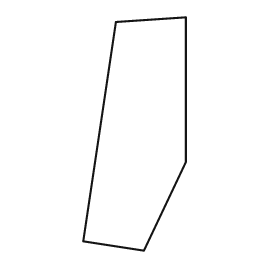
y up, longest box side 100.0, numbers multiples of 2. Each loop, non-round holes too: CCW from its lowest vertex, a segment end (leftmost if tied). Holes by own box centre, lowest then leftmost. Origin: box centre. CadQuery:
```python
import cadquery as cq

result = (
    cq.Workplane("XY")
    .moveTo(4.0, -50.0)
    .lineTo(22.0, -12.0)
    .lineTo(22.0, 50.0)
    .lineTo(-8.0, 48.0)
    .lineTo(-22.0, -46.0)
    .close()
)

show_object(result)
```